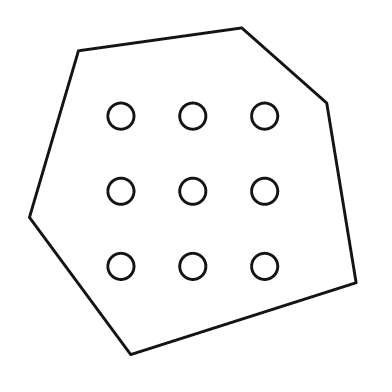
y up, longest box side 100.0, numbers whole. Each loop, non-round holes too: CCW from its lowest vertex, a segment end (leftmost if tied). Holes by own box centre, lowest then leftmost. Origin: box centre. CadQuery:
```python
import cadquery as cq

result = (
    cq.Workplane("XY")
    .moveTo(-19.0, -50.0)
    .lineTo(50.0, -28.0)
    .lineTo(41.0, 27.0)
    .lineTo(15.0, 50.0)
    .lineTo(-35.0, 43.0)
    .lineTo(-50.0, -8.0)
    .close()
    .moveTo(-22.0, -23.0)
    .circle(4.0)
    .moveTo(0.0, -23.0)
    .circle(4.0)
    .moveTo(22.0, -23.0)
    .circle(4.0)
    .moveTo(-22.0, 0.0)
    .circle(4.0)
    .moveTo(0.0, 0.0)
    .circle(4.0)
    .moveTo(22.0, 0.0)
    .circle(4.0)
    .moveTo(-22.0, 23.0)
    .circle(4.0)
    .moveTo(0.0, 23.0)
    .circle(4.0)
    .moveTo(22.0, 23.0)
    .circle(4.0)
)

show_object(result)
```